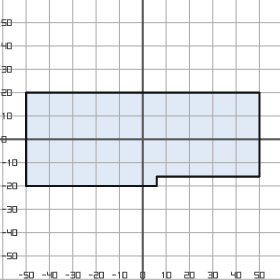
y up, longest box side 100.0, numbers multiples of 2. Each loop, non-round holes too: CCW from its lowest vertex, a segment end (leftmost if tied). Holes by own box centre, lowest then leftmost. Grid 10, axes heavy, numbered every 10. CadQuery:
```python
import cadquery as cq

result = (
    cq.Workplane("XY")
    .moveTo(-50.0, -20.0)
    .lineTo(6.0, -20.0)
    .lineTo(6.0, -16.0)
    .lineTo(50.0, -16.0)
    .lineTo(50.0, 20.0)
    .lineTo(-50.0, 20.0)
    .close()
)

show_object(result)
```